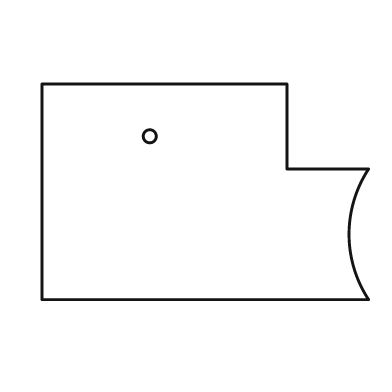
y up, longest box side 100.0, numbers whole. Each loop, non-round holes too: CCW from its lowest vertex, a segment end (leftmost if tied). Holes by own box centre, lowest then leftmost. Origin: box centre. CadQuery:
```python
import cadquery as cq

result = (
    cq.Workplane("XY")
    .moveTo(-50.0, -33.0)
    .lineTo(50.0, -33.0)
    .threePointArc((44.0, -13.0), (50.0, 7.0))
    .lineTo(25.0, 7.0)
    .lineTo(25.0, 33.0)
    .lineTo(-50.0, 33.0)
    .close()
    .moveTo(-17.0, 17.0)
    .circle(2.0)
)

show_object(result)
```